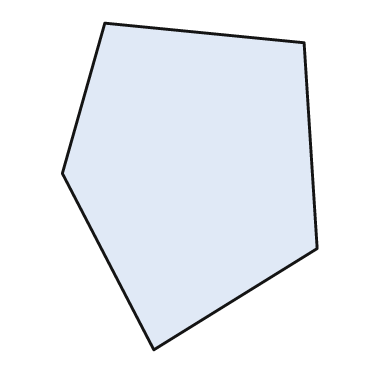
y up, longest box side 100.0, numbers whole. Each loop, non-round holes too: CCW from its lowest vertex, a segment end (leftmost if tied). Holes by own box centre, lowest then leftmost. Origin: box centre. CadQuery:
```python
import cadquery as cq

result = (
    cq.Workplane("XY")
    .moveTo(-11.0, -50.0)
    .lineTo(39.0, -19.0)
    .lineTo(35.0, 44.0)
    .lineTo(-26.0, 50.0)
    .lineTo(-39.0, 4.0)
    .close()
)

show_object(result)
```